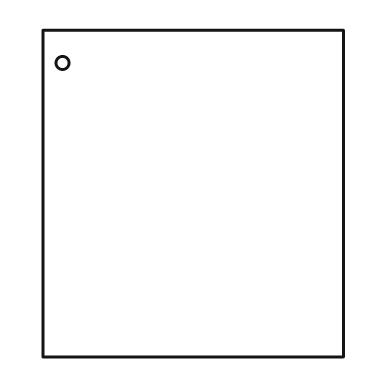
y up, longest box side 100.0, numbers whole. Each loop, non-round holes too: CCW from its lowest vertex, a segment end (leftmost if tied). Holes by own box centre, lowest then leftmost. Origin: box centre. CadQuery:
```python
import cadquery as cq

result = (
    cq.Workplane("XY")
    .moveTo(-46.0, -50.0)
    .lineTo(46.0, -50.0)
    .lineTo(46.0, 50.0)
    .lineTo(-46.0, 50.0)
    .close()
    .moveTo(-40.0, 40.0)
    .circle(2.0)
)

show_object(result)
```